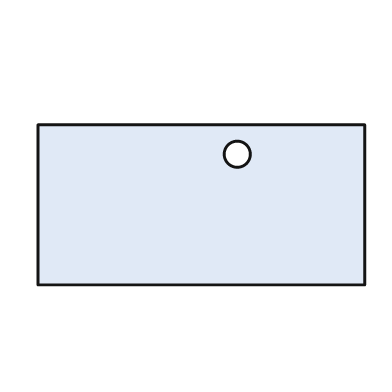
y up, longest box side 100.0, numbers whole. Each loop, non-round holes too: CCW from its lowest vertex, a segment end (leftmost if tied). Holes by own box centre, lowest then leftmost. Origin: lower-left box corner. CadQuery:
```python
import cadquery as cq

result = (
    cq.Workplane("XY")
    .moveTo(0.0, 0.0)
    .lineTo(100.0, 0.0)
    .lineTo(100.0, 49.0)
    .lineTo(0.0, 49.0)
    .close()
    .moveTo(61.0, 40.0)
    .circle(4.0)
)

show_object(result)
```